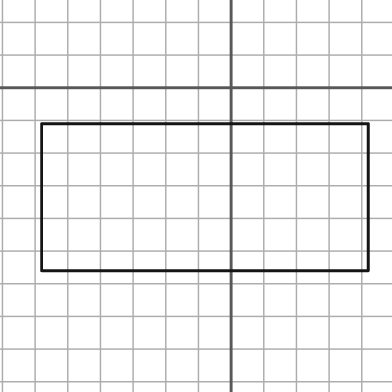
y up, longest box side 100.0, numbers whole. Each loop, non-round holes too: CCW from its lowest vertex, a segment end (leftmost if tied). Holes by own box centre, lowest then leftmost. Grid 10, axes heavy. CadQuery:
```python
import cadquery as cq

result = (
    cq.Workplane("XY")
    .moveTo(-58.0, -56.0)
    .lineTo(42.0, -56.0)
    .lineTo(42.0, -11.0)
    .lineTo(-58.0, -11.0)
    .close()
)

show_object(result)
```